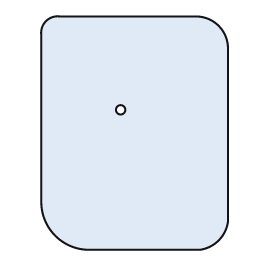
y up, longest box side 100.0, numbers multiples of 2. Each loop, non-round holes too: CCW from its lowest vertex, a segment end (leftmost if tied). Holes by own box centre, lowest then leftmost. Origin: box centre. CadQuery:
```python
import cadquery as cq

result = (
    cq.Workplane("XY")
    .moveTo(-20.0, -50.0)
    .lineTo(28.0, -50.0)
    .threePointArc((36.0, -46.0), (40.0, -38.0))
    .lineTo(40.0, 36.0)
    .threePointArc((36.0, 46.0), (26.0, 50.0))
    .lineTo(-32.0, 50.0)
    .threePointArc((-38.0, 48.0), (-40.0, 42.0))
    .lineTo(-40.0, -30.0)
    .threePointArc((-34.0, -44.0), (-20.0, -50.0))
    .close()
    .moveTo(-6.0, 10.0)
    .circle(2.0)
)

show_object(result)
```